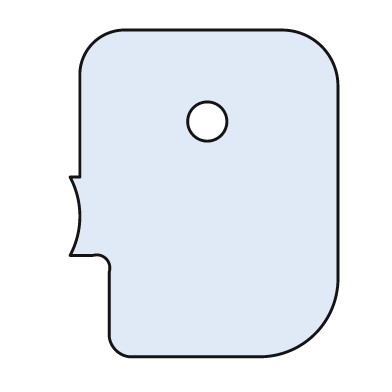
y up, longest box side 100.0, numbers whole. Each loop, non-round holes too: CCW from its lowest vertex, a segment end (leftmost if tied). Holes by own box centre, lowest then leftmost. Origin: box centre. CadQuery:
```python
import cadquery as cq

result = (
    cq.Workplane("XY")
    .moveTo(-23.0, -50.0)
    .lineTo(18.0, -50.0)
    .threePointArc((34.0, -43.0), (41.0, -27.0))
    .lineTo(41.0, 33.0)
    .threePointArc((36.0, 45.0), (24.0, 50.0))
    .lineTo(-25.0, 50.0)
    .threePointArc((-34.0, 46.0), (-38.0, 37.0))
    .lineTo(-38.0, 5.0)
    .lineTo(-41.0, 5.0)
    .threePointArc((-38.0, -7.0), (-41.0, -19.0))
    .lineTo(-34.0, -19.0)
    .threePointArc((-30.0, -20.0), (-29.0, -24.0))
    .lineTo(-29.0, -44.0)
    .threePointArc((-27.0, -48.0), (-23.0, -50.0))
    .close()
    .moveTo(1.0, 22.0)
    .circle(6.0)
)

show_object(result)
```